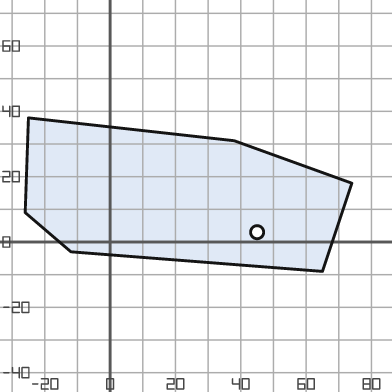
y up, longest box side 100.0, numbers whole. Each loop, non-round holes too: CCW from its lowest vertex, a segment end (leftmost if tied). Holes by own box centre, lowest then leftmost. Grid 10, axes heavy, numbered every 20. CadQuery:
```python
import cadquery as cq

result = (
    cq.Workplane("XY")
    .moveTo(65.0, -9.0)
    .lineTo(74.0, 18.0)
    .lineTo(38.0, 31.0)
    .lineTo(-25.0, 38.0)
    .lineTo(-26.0, 9.0)
    .lineTo(-12.0, -3.0)
    .close()
    .moveTo(45.0, 3.0)
    .circle(2.0)
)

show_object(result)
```